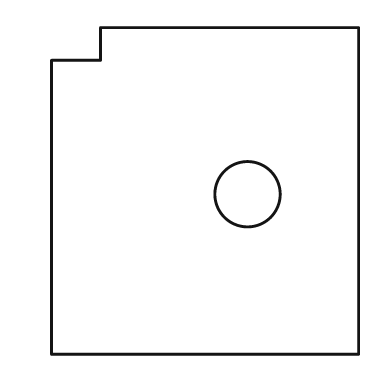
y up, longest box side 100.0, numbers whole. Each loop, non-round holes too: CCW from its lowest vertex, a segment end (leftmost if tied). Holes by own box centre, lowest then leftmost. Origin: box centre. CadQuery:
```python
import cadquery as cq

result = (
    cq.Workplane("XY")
    .moveTo(-47.0, -50.0)
    .lineTo(47.0, -50.0)
    .lineTo(47.0, 50.0)
    .lineTo(-32.0, 50.0)
    .lineTo(-32.0, 40.0)
    .lineTo(-47.0, 40.0)
    .close()
    .moveTo(13.0, -1.0)
    .circle(10.0)
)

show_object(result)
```